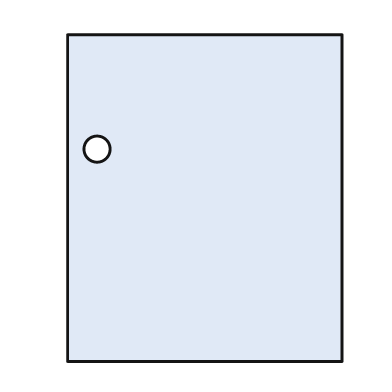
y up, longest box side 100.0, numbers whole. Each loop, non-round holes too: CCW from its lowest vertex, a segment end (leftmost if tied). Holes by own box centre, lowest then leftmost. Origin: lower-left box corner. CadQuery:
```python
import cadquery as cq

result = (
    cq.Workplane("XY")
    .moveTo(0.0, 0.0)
    .lineTo(84.0, 0.0)
    .lineTo(84.0, 100.0)
    .lineTo(0.0, 100.0)
    .close()
    .moveTo(9.0, 65.0)
    .circle(4.0)
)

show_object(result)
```